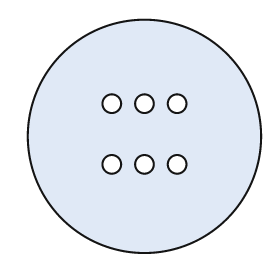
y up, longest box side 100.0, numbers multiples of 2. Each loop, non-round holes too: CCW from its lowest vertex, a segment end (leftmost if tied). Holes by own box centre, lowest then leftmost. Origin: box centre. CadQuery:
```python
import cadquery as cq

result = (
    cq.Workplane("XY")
    .moveTo(0.0, 0.0)
    .circle(50.0)
    .moveTo(-14.0, -12.0)
    .circle(4.0)
    .moveTo(0.0, -12.0)
    .circle(4.0)
    .moveTo(14.0, -12.0)
    .circle(4.0)
    .moveTo(-14.0, 14.0)
    .circle(4.0)
    .moveTo(0.0, 14.0)
    .circle(4.0)
    .moveTo(14.0, 14.0)
    .circle(4.0)
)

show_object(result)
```